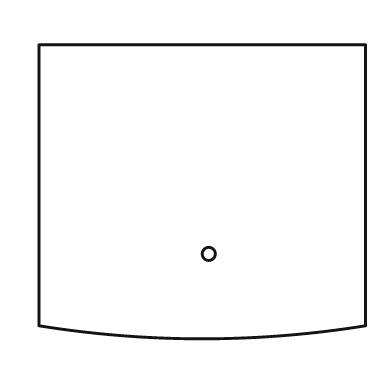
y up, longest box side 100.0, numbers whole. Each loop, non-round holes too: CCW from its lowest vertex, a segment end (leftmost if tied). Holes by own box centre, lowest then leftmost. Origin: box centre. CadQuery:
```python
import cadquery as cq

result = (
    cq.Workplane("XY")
    .moveTo(-50.0, -41.0)
    .threePointArc((0.0, -45.0), (50.0, -41.0))
    .lineTo(50.0, 45.0)
    .lineTo(-50.0, 45.0)
    .close()
    .moveTo(2.0, -19.0)
    .circle(2.0)
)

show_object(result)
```